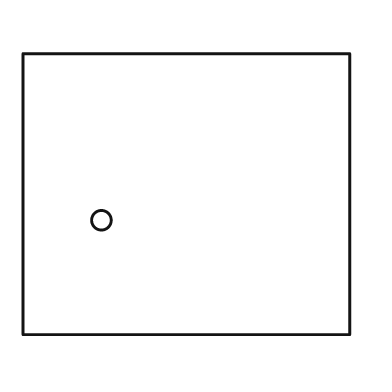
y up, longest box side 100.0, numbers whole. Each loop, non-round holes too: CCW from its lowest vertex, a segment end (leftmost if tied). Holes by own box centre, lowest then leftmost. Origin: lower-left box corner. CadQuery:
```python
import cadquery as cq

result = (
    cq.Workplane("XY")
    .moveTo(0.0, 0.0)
    .lineTo(100.0, 0.0)
    .lineTo(100.0, 86.0)
    .lineTo(0.0, 86.0)
    .close()
    .moveTo(24.0, 35.0)
    .circle(3.0)
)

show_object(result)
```